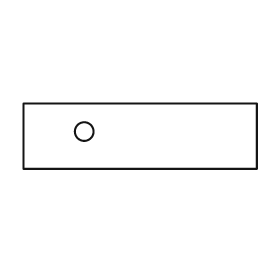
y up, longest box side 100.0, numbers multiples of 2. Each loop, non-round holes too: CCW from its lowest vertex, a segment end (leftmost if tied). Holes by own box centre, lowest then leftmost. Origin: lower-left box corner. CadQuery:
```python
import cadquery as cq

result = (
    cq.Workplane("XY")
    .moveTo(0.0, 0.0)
    .lineTo(100.0, 0.0)
    .lineTo(100.0, 28.0)
    .lineTo(0.0, 28.0)
    .close()
    .moveTo(26.0, 16.0)
    .circle(4.0)
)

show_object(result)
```